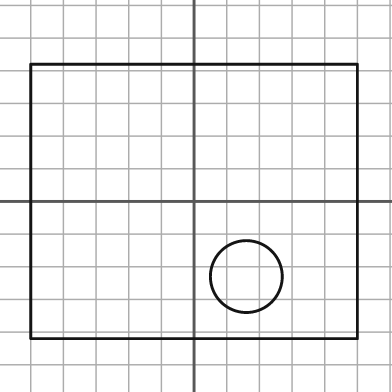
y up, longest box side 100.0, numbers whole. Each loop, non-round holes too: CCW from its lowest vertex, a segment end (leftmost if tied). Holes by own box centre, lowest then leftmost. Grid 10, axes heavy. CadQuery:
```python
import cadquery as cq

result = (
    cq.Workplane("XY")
    .moveTo(-50.0, -42.0)
    .lineTo(50.0, -42.0)
    .lineTo(50.0, 42.0)
    .lineTo(-50.0, 42.0)
    .close()
    .moveTo(16.0, -23.0)
    .circle(11.0)
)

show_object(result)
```